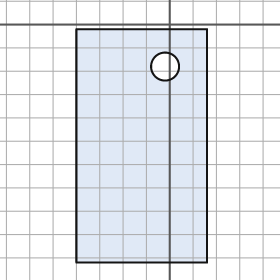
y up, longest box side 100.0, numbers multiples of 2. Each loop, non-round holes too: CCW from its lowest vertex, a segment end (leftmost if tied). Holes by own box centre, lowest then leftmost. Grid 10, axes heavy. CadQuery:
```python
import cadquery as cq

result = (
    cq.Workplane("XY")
    .moveTo(-40.0, -102.0)
    .lineTo(16.0, -102.0)
    .lineTo(16.0, -2.0)
    .lineTo(-40.0, -2.0)
    .close()
    .moveTo(-2.0, -18.0)
    .circle(6.0)
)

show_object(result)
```